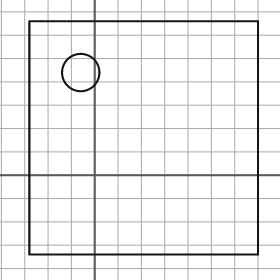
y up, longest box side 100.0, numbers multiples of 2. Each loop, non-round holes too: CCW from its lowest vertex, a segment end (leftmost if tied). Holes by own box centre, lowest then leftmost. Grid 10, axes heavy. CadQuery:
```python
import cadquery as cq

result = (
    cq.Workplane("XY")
    .moveTo(-28.0, -34.0)
    .lineTo(70.0, -34.0)
    .lineTo(70.0, 66.0)
    .lineTo(-28.0, 66.0)
    .close()
    .moveTo(-6.0, 44.0)
    .circle(8.0)
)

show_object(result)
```